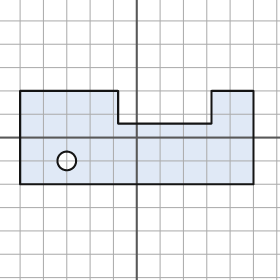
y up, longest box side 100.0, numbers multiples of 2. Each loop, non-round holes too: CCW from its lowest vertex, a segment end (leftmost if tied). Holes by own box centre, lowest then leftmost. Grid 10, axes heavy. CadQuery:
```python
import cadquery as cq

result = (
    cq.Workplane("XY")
    .moveTo(-50.0, -20.0)
    .lineTo(50.0, -20.0)
    .lineTo(50.0, 20.0)
    .lineTo(32.0, 20.0)
    .lineTo(32.0, 6.0)
    .lineTo(-8.0, 6.0)
    .lineTo(-8.0, 20.0)
    .lineTo(-50.0, 20.0)
    .close()
    .moveTo(-30.0, -10.0)
    .circle(4.0)
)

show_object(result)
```